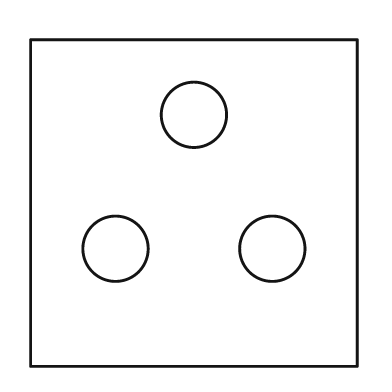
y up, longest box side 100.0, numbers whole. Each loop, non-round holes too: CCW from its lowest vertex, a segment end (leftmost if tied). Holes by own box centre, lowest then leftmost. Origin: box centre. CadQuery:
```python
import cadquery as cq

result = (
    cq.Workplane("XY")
    .moveTo(-50.0, -50.0)
    .lineTo(50.0, -50.0)
    .lineTo(50.0, 50.0)
    .lineTo(-50.0, 50.0)
    .close()
    .moveTo(-24.0, -14.0)
    .circle(10.0)
    .moveTo(24.0, -14.0)
    .circle(10.0)
    .moveTo(0.0, 27.0)
    .circle(10.0)
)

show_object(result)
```